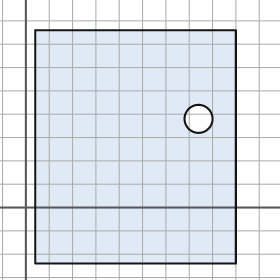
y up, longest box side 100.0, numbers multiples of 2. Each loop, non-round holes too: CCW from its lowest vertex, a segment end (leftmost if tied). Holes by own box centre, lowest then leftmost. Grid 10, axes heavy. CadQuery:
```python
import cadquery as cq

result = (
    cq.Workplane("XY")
    .moveTo(4.0, -24.0)
    .lineTo(90.0, -24.0)
    .lineTo(90.0, 76.0)
    .lineTo(4.0, 76.0)
    .close()
    .moveTo(74.0, 38.0)
    .circle(6.0)
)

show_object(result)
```